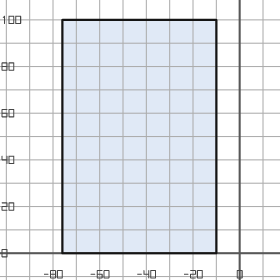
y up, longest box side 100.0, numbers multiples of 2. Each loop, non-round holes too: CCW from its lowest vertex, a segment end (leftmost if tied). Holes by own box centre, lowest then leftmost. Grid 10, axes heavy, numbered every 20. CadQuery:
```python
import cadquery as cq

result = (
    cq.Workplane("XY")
    .moveTo(-76.0, 0.0)
    .lineTo(-10.0, 0.0)
    .lineTo(-10.0, 100.0)
    .lineTo(-76.0, 100.0)
    .close()
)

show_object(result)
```